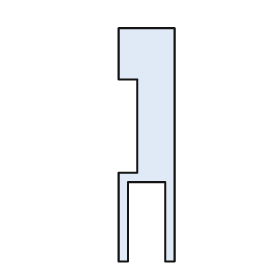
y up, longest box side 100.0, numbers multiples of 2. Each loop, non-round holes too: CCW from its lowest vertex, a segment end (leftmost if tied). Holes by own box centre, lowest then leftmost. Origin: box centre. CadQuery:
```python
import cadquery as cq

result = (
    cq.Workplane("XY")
    .moveTo(-12.0, -50.0)
    .lineTo(-8.0, -50.0)
    .lineTo(-8.0, -16.0)
    .lineTo(8.0, -16.0)
    .lineTo(8.0, -50.0)
    .lineTo(12.0, -50.0)
    .lineTo(12.0, 50.0)
    .lineTo(-12.0, 50.0)
    .lineTo(-12.0, 28.0)
    .lineTo(-4.0, 28.0)
    .lineTo(-4.0, -12.0)
    .lineTo(-12.0, -12.0)
    .close()
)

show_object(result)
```